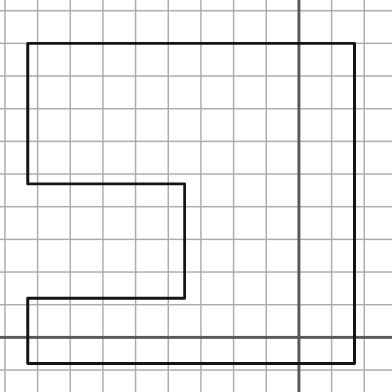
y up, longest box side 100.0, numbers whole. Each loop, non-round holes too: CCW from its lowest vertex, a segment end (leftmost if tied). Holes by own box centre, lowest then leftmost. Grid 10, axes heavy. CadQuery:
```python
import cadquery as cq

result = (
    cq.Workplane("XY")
    .moveTo(-83.0, -8.0)
    .lineTo(17.0, -8.0)
    .lineTo(17.0, 90.0)
    .lineTo(-83.0, 90.0)
    .lineTo(-83.0, 47.0)
    .lineTo(-35.0, 47.0)
    .lineTo(-35.0, 12.0)
    .lineTo(-83.0, 12.0)
    .close()
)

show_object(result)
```